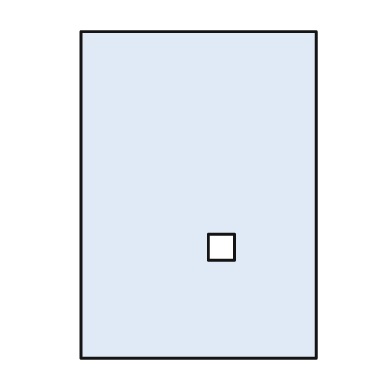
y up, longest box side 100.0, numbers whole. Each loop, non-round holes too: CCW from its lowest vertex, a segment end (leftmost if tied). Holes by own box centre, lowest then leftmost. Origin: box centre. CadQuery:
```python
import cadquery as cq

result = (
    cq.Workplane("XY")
    .moveTo(-36.0, -50.0)
    .lineTo(36.0, -50.0)
    .lineTo(36.0, 50.0)
    .lineTo(-36.0, 50.0)
    .close()
    .moveTo(3.0, -20.0)
    .lineTo(11.0, -20.0)
    .lineTo(11.0, -12.0)
    .lineTo(3.0, -12.0)
    .close()
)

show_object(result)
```